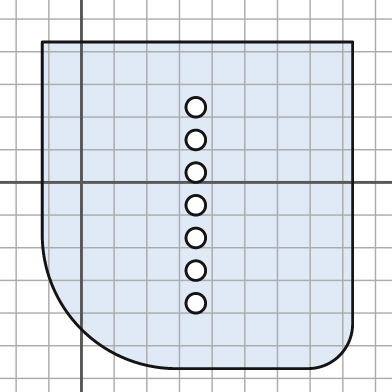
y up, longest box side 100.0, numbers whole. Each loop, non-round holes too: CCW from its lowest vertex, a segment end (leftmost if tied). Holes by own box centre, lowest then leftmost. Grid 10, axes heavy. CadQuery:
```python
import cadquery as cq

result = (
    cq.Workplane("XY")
    .moveTo(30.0, -57.0)
    .lineTo(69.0, -57.0)
    .threePointArc((79.0, -53.0), (83.0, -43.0))
    .lineTo(83.0, 43.0)
    .lineTo(-12.0, 43.0)
    .lineTo(-12.0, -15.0)
    .threePointArc((0.0, -45.0), (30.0, -57.0))
    .close()
    .moveTo(35.0, -37.0)
    .circle(3.0)
    .moveTo(35.0, -27.0)
    .circle(3.0)
    .moveTo(35.0, -17.0)
    .circle(3.0)
    .moveTo(35.0, -7.0)
    .circle(3.0)
    .moveTo(35.0, 3.0)
    .circle(3.0)
    .moveTo(35.0, 13.0)
    .circle(3.0)
    .moveTo(35.0, 23.0)
    .circle(3.0)
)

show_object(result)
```